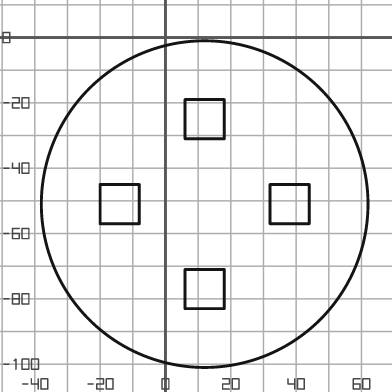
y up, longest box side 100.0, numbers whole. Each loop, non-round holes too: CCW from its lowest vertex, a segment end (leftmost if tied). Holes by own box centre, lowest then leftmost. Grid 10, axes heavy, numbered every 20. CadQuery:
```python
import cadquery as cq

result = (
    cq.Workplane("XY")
    .moveTo(12.0, -51.0)
    .circle(50.0)
    .moveTo(6.0, -83.0)
    .lineTo(18.0, -83.0)
    .lineTo(18.0, -71.0)
    .lineTo(6.0, -71.0)
    .close()
    .moveTo(-20.0, -57.0)
    .lineTo(-8.0, -57.0)
    .lineTo(-8.0, -45.0)
    .lineTo(-20.0, -45.0)
    .close()
    .moveTo(32.0, -57.0)
    .lineTo(44.0, -57.0)
    .lineTo(44.0, -45.0)
    .lineTo(32.0, -45.0)
    .close()
    .moveTo(6.0, -31.0)
    .lineTo(18.0, -31.0)
    .lineTo(18.0, -19.0)
    .lineTo(6.0, -19.0)
    .close()
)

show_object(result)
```